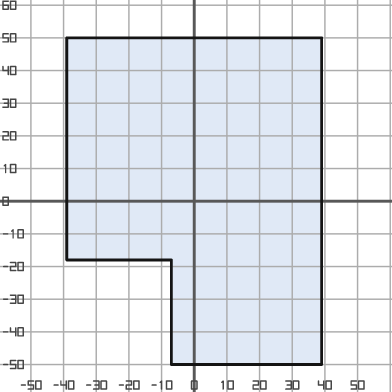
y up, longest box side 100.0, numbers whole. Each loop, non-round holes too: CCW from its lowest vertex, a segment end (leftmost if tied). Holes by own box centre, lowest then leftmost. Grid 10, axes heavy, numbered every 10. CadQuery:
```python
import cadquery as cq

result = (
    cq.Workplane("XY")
    .moveTo(-7.0, -50.0)
    .lineTo(39.0, -50.0)
    .lineTo(39.0, 50.0)
    .lineTo(-39.0, 50.0)
    .lineTo(-39.0, -18.0)
    .lineTo(-7.0, -18.0)
    .close()
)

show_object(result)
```